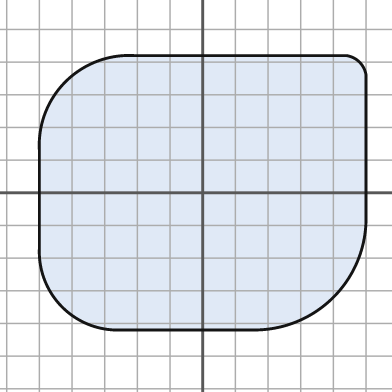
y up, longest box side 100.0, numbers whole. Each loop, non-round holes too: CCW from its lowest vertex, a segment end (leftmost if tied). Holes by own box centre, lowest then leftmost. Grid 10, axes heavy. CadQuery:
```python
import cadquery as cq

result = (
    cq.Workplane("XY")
    .moveTo(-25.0, -42.0)
    .lineTo(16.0, -42.0)
    .threePointArc((40.0, -32.0), (50.0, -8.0))
    .lineTo(50.0, 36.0)
    .threePointArc((48.0, 40.0), (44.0, 42.0))
    .lineTo(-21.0, 42.0)
    .threePointArc((-42.0, 34.0), (-50.0, 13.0))
    .lineTo(-50.0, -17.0)
    .threePointArc((-43.0, -35.0), (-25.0, -42.0))
    .close()
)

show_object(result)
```